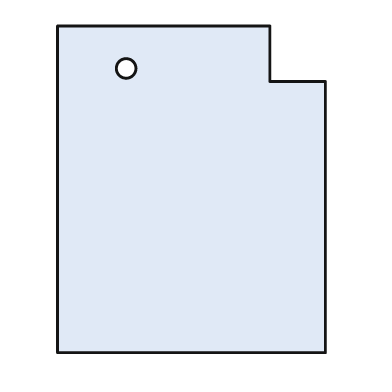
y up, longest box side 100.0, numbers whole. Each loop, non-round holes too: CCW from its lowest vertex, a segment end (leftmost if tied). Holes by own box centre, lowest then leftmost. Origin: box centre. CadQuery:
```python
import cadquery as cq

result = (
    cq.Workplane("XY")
    .moveTo(-41.0, -50.0)
    .lineTo(41.0, -50.0)
    .lineTo(41.0, 33.0)
    .lineTo(24.0, 33.0)
    .lineTo(24.0, 50.0)
    .lineTo(-41.0, 50.0)
    .close()
    .moveTo(-20.0, 37.0)
    .circle(3.0)
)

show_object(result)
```